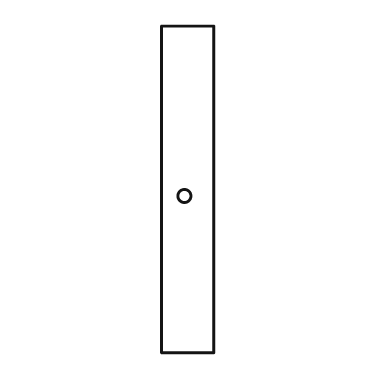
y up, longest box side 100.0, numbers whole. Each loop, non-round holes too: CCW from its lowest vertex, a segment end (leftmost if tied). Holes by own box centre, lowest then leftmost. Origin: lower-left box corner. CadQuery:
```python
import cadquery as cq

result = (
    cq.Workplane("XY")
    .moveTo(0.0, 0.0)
    .lineTo(16.0, 0.0)
    .lineTo(16.0, 100.0)
    .lineTo(0.0, 100.0)
    .close()
    .moveTo(7.0, 48.0)
    .circle(2.0)
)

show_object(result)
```